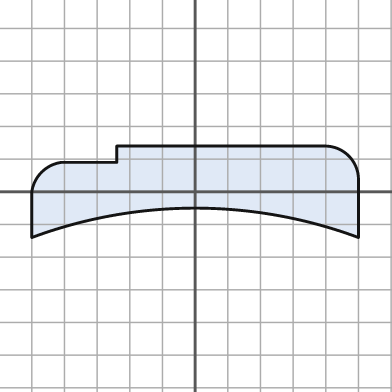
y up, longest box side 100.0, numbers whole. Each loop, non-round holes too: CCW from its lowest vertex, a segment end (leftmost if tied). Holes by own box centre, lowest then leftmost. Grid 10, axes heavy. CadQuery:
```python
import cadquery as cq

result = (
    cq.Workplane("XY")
    .moveTo(-50.0, -14.0)
    .threePointArc((0.0, -5.0), (50.0, -14.0))
    .lineTo(50.0, 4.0)
    .threePointArc((47.0, 11.0), (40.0, 14.0))
    .lineTo(-24.0, 14.0)
    .lineTo(-24.0, 9.0)
    .lineTo(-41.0, 9.0)
    .threePointArc((-47.0, 6.0), (-50.0, 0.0))
    .close()
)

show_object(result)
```